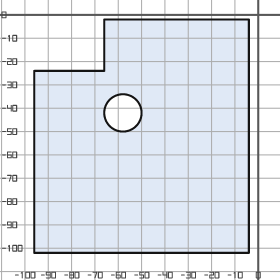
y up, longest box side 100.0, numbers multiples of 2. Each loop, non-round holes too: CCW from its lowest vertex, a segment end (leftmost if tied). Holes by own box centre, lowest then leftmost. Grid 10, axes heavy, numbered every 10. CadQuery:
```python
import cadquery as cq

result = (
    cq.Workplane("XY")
    .moveTo(-96.0, -102.0)
    .lineTo(-4.0, -102.0)
    .lineTo(-4.0, -2.0)
    .lineTo(-66.0, -2.0)
    .lineTo(-66.0, -24.0)
    .lineTo(-96.0, -24.0)
    .close()
    .moveTo(-58.0, -42.0)
    .circle(8.0)
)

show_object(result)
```